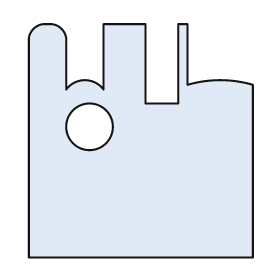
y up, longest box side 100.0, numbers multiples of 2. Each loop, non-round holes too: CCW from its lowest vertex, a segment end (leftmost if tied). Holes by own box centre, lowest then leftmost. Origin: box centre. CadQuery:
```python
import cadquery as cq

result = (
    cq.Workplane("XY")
    .moveTo(-48.0, -50.0)
    .lineTo(48.0, -50.0)
    .lineTo(48.0, 24.0)
    .threePointArc((34.0, 26.0), (20.0, 24.0))
    .lineTo(20.0, 50.0)
    .lineTo(16.0, 50.0)
    .lineTo(16.0, 16.0)
    .lineTo(2.0, 16.0)
    .lineTo(2.0, 50.0)
    .lineTo(-16.0, 50.0)
    .lineTo(-16.0, 22.0)
    .threePointArc((-24.0, 26.0), (-32.0, 22.0))
    .lineTo(-32.0, 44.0)
    .threePointArc((-34.0, 48.0), (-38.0, 50.0))
    .lineTo(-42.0, 50.0)
    .threePointArc((-46.0, 48.0), (-48.0, 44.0))
    .close()
    .moveTo(-22.0, 6.0)
    .circle(10.0)
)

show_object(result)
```